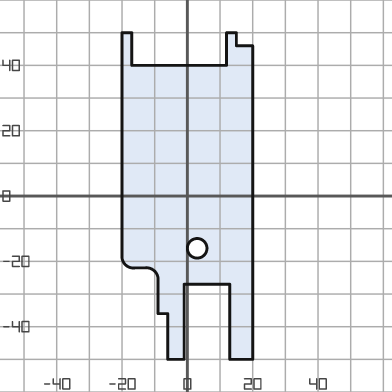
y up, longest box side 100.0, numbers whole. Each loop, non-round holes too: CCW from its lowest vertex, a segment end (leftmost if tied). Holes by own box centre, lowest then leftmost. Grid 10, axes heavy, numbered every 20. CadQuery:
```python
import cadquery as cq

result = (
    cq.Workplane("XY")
    .moveTo(-6.0, -50.0)
    .lineTo(-1.0, -50.0)
    .lineTo(-1.0, -27.0)
    .lineTo(13.0, -27.0)
    .lineTo(13.0, -50.0)
    .lineTo(20.0, -50.0)
    .lineTo(20.0, 46.0)
    .lineTo(15.0, 46.0)
    .lineTo(15.0, 50.0)
    .lineTo(12.0, 50.0)
    .lineTo(12.0, 40.0)
    .lineTo(-17.0, 40.0)
    .lineTo(-17.0, 50.0)
    .lineTo(-20.0, 50.0)
    .lineTo(-20.0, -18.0)
    .threePointArc((-19.0, -21.0), (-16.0, -22.0))
    .lineTo(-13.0, -22.0)
    .threePointArc((-10.0, -23.0), (-9.0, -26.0))
    .lineTo(-9.0, -36.0)
    .lineTo(-6.0, -36.0)
    .close()
    .moveTo(3.0, -16.0)
    .circle(3.0)
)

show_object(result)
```